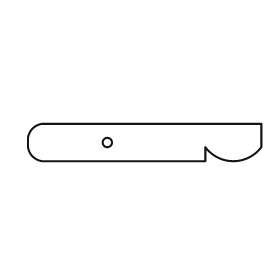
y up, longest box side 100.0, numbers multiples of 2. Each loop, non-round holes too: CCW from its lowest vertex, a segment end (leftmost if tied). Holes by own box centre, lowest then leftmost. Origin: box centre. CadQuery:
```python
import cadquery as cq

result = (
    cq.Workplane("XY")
    .moveTo(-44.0, -8.0)
    .lineTo(26.0, -8.0)
    .lineTo(26.0, -2.0)
    .threePointArc((38.0, -8.0), (50.0, -2.0))
    .lineTo(50.0, 8.0)
    .lineTo(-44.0, 8.0)
    .threePointArc((-48.0, 6.0), (-50.0, 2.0))
    .lineTo(-50.0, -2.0)
    .threePointArc((-48.0, -6.0), (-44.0, -8.0))
    .close()
    .moveTo(-16.0, 0.0)
    .circle(2.0)
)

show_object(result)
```